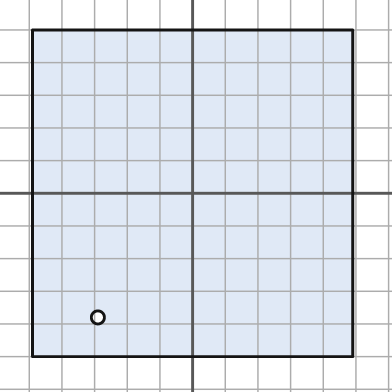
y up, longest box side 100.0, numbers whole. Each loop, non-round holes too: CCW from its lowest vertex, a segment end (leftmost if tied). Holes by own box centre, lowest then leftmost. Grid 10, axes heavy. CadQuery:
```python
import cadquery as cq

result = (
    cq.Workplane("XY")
    .moveTo(-49.0, -50.0)
    .lineTo(49.0, -50.0)
    .lineTo(49.0, 50.0)
    .lineTo(-49.0, 50.0)
    .close()
    .moveTo(-29.0, -38.0)
    .circle(2.0)
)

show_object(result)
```